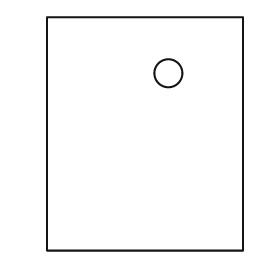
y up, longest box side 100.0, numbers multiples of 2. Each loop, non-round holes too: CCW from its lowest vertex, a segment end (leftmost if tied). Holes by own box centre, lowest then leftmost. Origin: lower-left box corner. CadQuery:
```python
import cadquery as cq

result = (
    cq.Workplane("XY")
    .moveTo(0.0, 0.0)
    .lineTo(84.0, 0.0)
    .lineTo(84.0, 100.0)
    .lineTo(0.0, 100.0)
    .close()
    .moveTo(52.0, 76.0)
    .circle(6.0)
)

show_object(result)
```